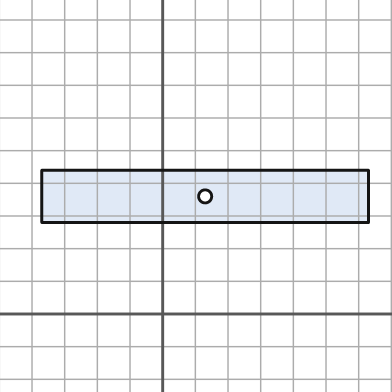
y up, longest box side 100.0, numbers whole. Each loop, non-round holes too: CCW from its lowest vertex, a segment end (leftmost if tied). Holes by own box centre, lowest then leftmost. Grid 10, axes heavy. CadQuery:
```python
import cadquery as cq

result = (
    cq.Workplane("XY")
    .moveTo(-37.0, 28.0)
    .lineTo(63.0, 28.0)
    .lineTo(63.0, 44.0)
    .lineTo(-37.0, 44.0)
    .close()
    .moveTo(13.0, 36.0)
    .circle(2.0)
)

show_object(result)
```